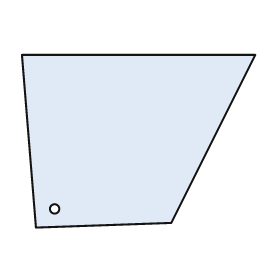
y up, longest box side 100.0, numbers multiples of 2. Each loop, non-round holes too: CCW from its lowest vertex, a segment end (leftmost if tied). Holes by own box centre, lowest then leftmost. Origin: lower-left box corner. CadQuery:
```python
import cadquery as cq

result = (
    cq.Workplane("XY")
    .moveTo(6.0, 0.0)
    .lineTo(64.0, 2.0)
    .lineTo(100.0, 74.0)
    .lineTo(0.0, 74.0)
    .close()
    .moveTo(14.0, 8.0)
    .circle(2.0)
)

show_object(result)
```